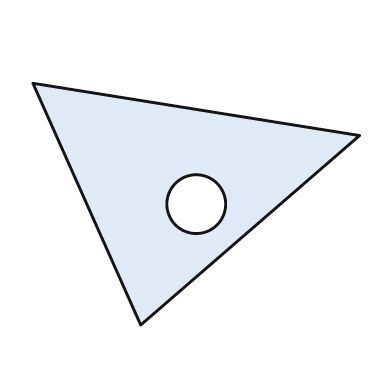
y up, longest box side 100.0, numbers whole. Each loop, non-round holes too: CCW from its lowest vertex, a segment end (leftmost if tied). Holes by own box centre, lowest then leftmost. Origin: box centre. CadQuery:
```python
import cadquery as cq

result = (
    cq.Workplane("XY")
    .moveTo(-17.0, -37.0)
    .lineTo(50.0, 21.0)
    .lineTo(-50.0, 37.0)
    .close()
    .moveTo(0.0, 0.0)
    .circle(9.0)
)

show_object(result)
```